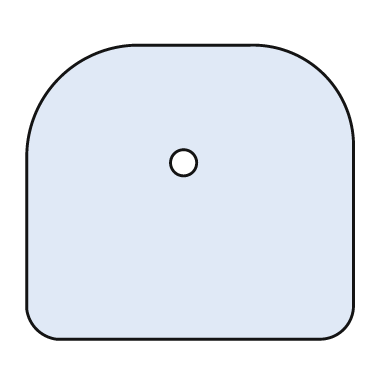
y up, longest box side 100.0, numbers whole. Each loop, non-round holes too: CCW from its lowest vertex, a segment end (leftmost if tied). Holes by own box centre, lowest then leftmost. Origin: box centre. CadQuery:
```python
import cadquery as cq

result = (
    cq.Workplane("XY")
    .moveTo(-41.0, -45.0)
    .lineTo(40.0, -45.0)
    .threePointArc((47.0, -42.0), (50.0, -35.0))
    .lineTo(50.0, 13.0)
    .threePointArc((41.0, 36.0), (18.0, 45.0))
    .lineTo(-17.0, 45.0)
    .threePointArc((-40.0, 35.0), (-50.0, 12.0))
    .lineTo(-50.0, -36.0)
    .threePointArc((-47.0, -42.0), (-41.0, -45.0))
    .close()
    .moveTo(-2.0, 9.0)
    .circle(4.0)
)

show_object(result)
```